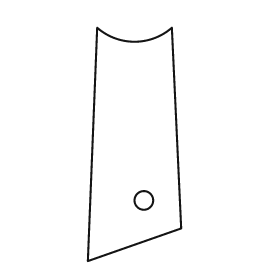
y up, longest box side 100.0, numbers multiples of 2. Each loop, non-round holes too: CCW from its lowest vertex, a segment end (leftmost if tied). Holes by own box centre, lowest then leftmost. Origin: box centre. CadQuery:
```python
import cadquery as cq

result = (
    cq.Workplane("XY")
    .moveTo(-20.0, -50.0)
    .lineTo(20.0, -36.0)
    .lineTo(16.0, 50.0)
    .threePointArc((0.0, 44.0), (-16.0, 50.0))
    .close()
    .moveTo(4.0, -24.0)
    .circle(4.0)
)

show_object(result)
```